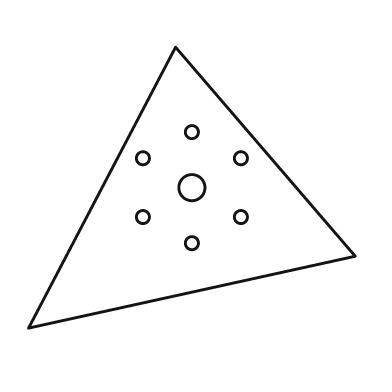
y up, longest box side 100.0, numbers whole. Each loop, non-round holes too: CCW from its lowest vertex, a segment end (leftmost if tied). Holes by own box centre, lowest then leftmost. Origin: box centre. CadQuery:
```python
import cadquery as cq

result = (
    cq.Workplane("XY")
    .moveTo(-50.0, -43.0)
    .lineTo(50.0, -21.0)
    .lineTo(-5.0, 43.0)
    .close()
    .moveTo(0.0, -17.0)
    .circle(2.0)
    .moveTo(-15.0, -9.0)
    .circle(2.0)
    .moveTo(15.0, -9.0)
    .circle(2.0)
    .moveTo(0.0, 0.0)
    .circle(4.0)
    .moveTo(-15.0, 9.0)
    .circle(2.0)
    .moveTo(15.0, 9.0)
    .circle(2.0)
    .moveTo(0.0, 17.0)
    .circle(2.0)
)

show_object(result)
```